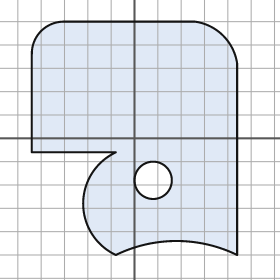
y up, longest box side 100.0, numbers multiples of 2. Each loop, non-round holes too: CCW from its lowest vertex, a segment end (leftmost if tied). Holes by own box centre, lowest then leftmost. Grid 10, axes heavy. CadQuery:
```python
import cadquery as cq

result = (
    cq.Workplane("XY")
    .moveTo(-8.0, -50.0)
    .threePointArc((18.0, -44.0), (44.0, -50.0))
    .lineTo(44.0, 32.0)
    .threePointArc((38.0, 44.0), (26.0, 50.0))
    .lineTo(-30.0, 50.0)
    .threePointArc((-40.0, 46.0), (-44.0, 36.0))
    .lineTo(-44.0, -6.0)
    .lineTo(-8.0, -6.0)
    .threePointArc((-22.0, -28.0), (-8.0, -50.0))
    .close()
    .moveTo(8.0, -18.0)
    .circle(8.0)
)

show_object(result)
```